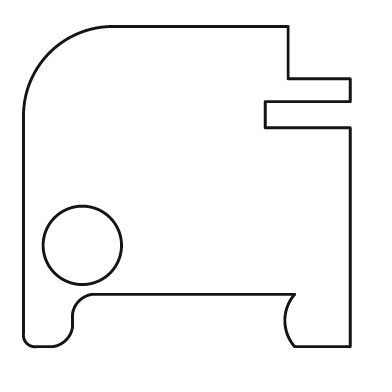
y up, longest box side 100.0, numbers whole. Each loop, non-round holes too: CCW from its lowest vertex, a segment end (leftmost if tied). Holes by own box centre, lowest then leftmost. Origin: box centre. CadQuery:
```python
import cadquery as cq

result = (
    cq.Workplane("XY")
    .moveTo(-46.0, -49.0)
    .lineTo(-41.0, -49.0)
    .threePointArc((-37.0, -47.0), (-35.0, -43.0))
    .lineTo(-35.0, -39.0)
    .threePointArc((-33.0, -35.0), (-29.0, -33.0))
    .lineTo(33.0, -33.0)
    .threePointArc((30.0, -41.0), (33.0, -49.0))
    .lineTo(50.0, -49.0)
    .lineTo(50.0, 18.0)
    .lineTo(24.0, 18.0)
    .lineTo(24.0, 26.0)
    .lineTo(50.0, 26.0)
    .lineTo(50.0, 33.0)
    .lineTo(31.0, 33.0)
    .lineTo(31.0, 49.0)
    .lineTo(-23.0, 49.0)
    .threePointArc((-42.0, 41.0), (-50.0, 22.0))
    .lineTo(-50.0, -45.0)
    .threePointArc((-49.0, -48.0), (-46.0, -49.0))
    .close()
    .moveTo(-32.0, -18.0)
    .circle(12.0)
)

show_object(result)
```